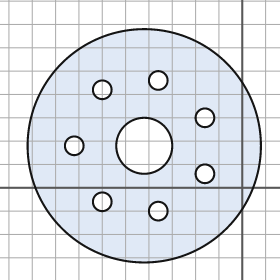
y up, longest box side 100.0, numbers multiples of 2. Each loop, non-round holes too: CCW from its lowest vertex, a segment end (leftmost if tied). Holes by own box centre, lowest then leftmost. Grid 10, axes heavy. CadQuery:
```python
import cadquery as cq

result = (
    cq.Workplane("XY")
    .moveTo(-42.0, 18.0)
    .circle(50.0)
    .moveTo(-36.0, -10.0)
    .circle(4.0)
    .moveTo(-60.0, -6.0)
    .circle(4.0)
    .moveTo(-16.0, 6.0)
    .circle(4.0)
    .moveTo(-72.0, 18.0)
    .circle(4.0)
    .moveTo(-42.0, 18.0)
    .circle(12.0)
    .moveTo(-16.0, 30.0)
    .circle(4.0)
    .moveTo(-60.0, 42.0)
    .circle(4.0)
    .moveTo(-36.0, 46.0)
    .circle(4.0)
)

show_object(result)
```